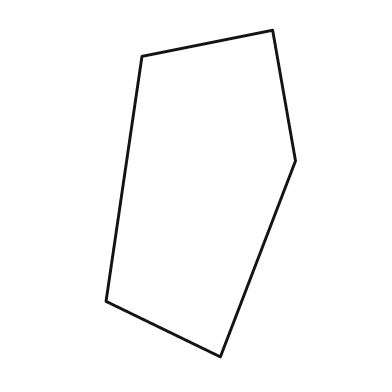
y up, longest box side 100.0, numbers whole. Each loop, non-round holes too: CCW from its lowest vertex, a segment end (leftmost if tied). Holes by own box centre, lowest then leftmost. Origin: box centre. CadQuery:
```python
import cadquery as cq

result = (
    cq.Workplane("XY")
    .moveTo(6.0, -50.0)
    .lineTo(29.0, 10.0)
    .lineTo(22.0, 50.0)
    .lineTo(-18.0, 42.0)
    .lineTo(-29.0, -33.0)
    .close()
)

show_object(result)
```